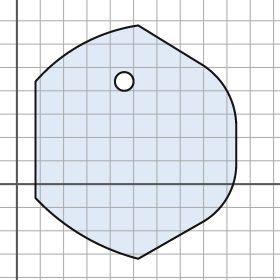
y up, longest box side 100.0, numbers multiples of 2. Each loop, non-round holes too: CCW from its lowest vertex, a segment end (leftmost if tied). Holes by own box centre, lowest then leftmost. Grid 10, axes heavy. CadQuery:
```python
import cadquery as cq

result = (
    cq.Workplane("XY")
    .moveTo(52.0, -32.0)
    .lineTo(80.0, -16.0)
    .threePointArc((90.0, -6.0), (94.0, 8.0))
    .lineTo(94.0, 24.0)
    .threePointArc((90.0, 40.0), (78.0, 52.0))
    .lineTo(52.0, 68.0)
    .threePointArc((28.0, 60.0), (8.0, 44.0))
    .lineTo(8.0, -6.0)
    .threePointArc((28.0, -22.0), (52.0, -32.0))
    .close()
    .moveTo(46.0, 44.0)
    .circle(4.0)
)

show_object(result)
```